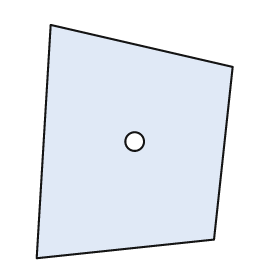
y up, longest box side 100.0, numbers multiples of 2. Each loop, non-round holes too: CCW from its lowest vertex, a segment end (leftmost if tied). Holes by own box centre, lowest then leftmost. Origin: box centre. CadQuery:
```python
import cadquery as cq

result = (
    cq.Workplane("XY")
    .moveTo(-42.0, -50.0)
    .lineTo(34.0, -42.0)
    .lineTo(42.0, 32.0)
    .lineTo(-36.0, 50.0)
    .close()
    .moveTo(0.0, 0.0)
    .circle(4.0)
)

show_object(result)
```